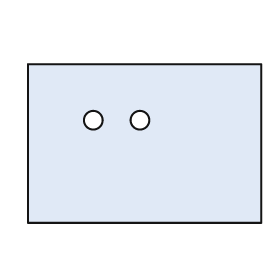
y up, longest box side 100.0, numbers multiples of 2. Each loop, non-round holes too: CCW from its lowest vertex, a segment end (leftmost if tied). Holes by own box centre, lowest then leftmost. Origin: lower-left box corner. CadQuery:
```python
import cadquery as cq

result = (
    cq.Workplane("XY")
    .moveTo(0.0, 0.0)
    .lineTo(100.0, 0.0)
    .lineTo(100.0, 68.0)
    .lineTo(0.0, 68.0)
    .close()
    .moveTo(28.0, 44.0)
    .circle(4.0)
    .moveTo(48.0, 44.0)
    .circle(4.0)
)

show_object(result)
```